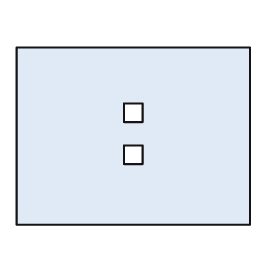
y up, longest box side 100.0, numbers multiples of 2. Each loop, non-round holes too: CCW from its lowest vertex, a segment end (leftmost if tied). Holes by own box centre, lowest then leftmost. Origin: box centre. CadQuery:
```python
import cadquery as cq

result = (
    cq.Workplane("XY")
    .moveTo(-50.0, -38.0)
    .lineTo(50.0, -38.0)
    .lineTo(50.0, 38.0)
    .lineTo(-50.0, 38.0)
    .close()
    .moveTo(-4.0, -12.0)
    .lineTo(4.0, -12.0)
    .lineTo(4.0, -4.0)
    .lineTo(-4.0, -4.0)
    .close()
    .moveTo(-4.0, 6.0)
    .lineTo(4.0, 6.0)
    .lineTo(4.0, 14.0)
    .lineTo(-4.0, 14.0)
    .close()
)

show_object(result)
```